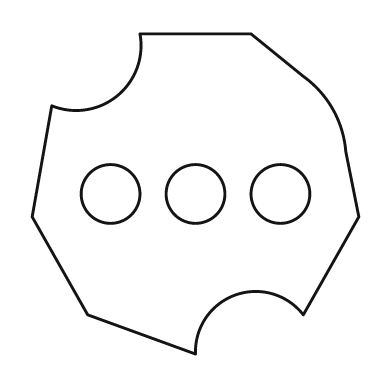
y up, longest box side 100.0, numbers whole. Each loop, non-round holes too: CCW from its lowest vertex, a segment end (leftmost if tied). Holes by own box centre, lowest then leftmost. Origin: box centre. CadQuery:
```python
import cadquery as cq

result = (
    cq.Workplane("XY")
    .moveTo(0.0, -49.0)
    .threePointArc((12.0, -31.0), (33.0, -37.0))
    .lineTo(50.0, -7.0)
    .lineTo(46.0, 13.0)
    .threePointArc((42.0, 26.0), (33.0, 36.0))
    .lineTo(17.0, 49.0)
    .lineTo(-17.0, 49.0)
    .threePointArc((-24.0, 30.0), (-44.0, 27.0))
    .lineTo(-50.0, -7.0)
    .lineTo(-33.0, -37.0)
    .close()
    .moveTo(-26.0, 0.0)
    .circle(9.0)
    .moveTo(0.0, 0.0)
    .circle(9.0)
    .moveTo(26.0, 0.0)
    .circle(9.0)
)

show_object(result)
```